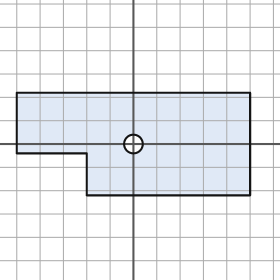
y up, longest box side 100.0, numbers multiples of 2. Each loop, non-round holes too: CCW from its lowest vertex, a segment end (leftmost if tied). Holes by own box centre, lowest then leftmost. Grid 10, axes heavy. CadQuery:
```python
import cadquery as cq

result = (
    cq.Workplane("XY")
    .moveTo(-20.0, -22.0)
    .lineTo(50.0, -22.0)
    .lineTo(50.0, 22.0)
    .lineTo(-50.0, 22.0)
    .lineTo(-50.0, -4.0)
    .lineTo(-20.0, -4.0)
    .close()
    .moveTo(0.0, 0.0)
    .circle(4.0)
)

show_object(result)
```